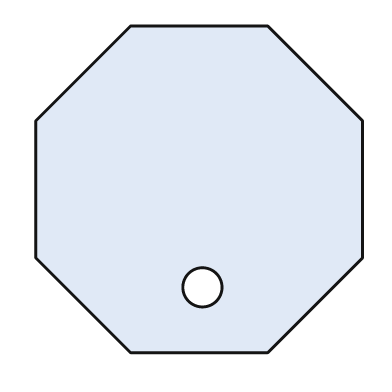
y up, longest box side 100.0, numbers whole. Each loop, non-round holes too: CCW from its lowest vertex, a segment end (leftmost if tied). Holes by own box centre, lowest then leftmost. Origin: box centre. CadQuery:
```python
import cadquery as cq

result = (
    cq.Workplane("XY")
    .moveTo(-21.0, -50.0)
    .lineTo(21.0, -50.0)
    .lineTo(50.0, -21.0)
    .lineTo(50.0, 21.0)
    .lineTo(21.0, 50.0)
    .lineTo(-21.0, 50.0)
    .lineTo(-50.0, 21.0)
    .lineTo(-50.0, -21.0)
    .close()
    .moveTo(1.0, -30.0)
    .circle(6.0)
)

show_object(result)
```